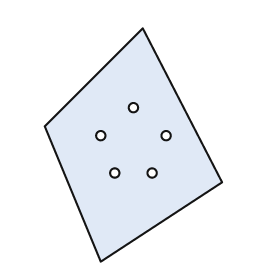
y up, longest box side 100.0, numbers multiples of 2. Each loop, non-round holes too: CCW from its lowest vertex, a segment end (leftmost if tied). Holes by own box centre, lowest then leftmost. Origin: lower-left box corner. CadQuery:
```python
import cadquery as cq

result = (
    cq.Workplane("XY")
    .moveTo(24.0, 0.0)
    .lineTo(76.0, 34.0)
    .lineTo(42.0, 100.0)
    .lineTo(0.0, 58.0)
    .close()
    .moveTo(30.0, 38.0)
    .circle(2.0)
    .moveTo(46.0, 38.0)
    .circle(2.0)
    .moveTo(24.0, 54.0)
    .circle(2.0)
    .moveTo(52.0, 54.0)
    .circle(2.0)
    .moveTo(38.0, 66.0)
    .circle(2.0)
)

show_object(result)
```